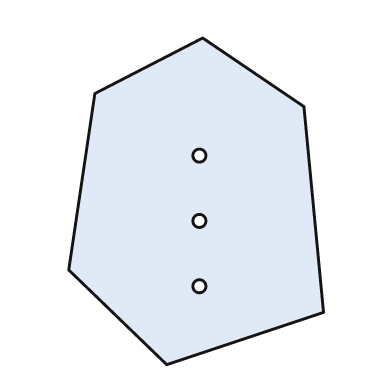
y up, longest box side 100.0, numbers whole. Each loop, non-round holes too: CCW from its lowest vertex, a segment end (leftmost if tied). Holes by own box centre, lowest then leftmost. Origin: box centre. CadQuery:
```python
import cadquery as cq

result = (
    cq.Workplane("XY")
    .moveTo(-9.0, -50.0)
    .lineTo(39.0, -34.0)
    .lineTo(33.0, 29.0)
    .lineTo(2.0, 50.0)
    .lineTo(-31.0, 33.0)
    .lineTo(-39.0, -21.0)
    .close()
    .moveTo(1.0, -26.0)
    .circle(2.0)
    .moveTo(1.0, -6.0)
    .circle(2.0)
    .moveTo(1.0, 14.0)
    .circle(2.0)
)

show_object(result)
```